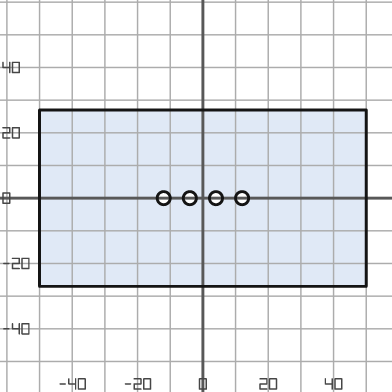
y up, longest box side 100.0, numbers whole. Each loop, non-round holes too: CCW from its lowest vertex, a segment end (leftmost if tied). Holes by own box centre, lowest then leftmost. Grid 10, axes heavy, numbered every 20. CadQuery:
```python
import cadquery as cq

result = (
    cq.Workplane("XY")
    .moveTo(-50.0, -27.0)
    .lineTo(50.0, -27.0)
    .lineTo(50.0, 27.0)
    .lineTo(-50.0, 27.0)
    .close()
    .moveTo(-12.0, 0.0)
    .circle(2.0)
    .moveTo(-4.0, 0.0)
    .circle(2.0)
    .moveTo(4.0, 0.0)
    .circle(2.0)
    .moveTo(12.0, 0.0)
    .circle(2.0)
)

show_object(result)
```